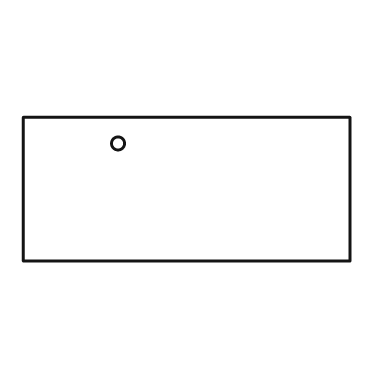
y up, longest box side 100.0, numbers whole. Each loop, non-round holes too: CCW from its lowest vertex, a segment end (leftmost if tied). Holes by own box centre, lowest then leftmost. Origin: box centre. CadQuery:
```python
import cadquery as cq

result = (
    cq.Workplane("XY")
    .moveTo(-50.0, -22.0)
    .lineTo(50.0, -22.0)
    .lineTo(50.0, 22.0)
    .lineTo(-50.0, 22.0)
    .close()
    .moveTo(-21.0, 14.0)
    .circle(2.0)
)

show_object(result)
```